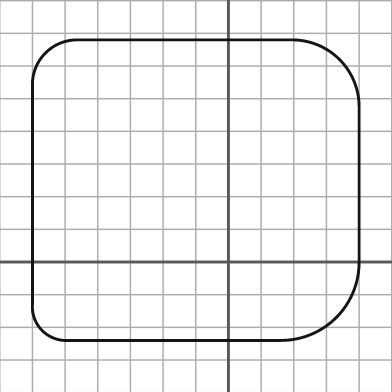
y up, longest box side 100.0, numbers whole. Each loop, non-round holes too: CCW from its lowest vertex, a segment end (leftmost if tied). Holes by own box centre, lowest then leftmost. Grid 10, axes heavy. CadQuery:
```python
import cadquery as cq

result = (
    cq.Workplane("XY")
    .moveTo(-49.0, -24.0)
    .lineTo(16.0, -24.0)
    .threePointArc((33.0, -17.0), (40.0, 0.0))
    .lineTo(40.0, 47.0)
    .threePointArc((34.0, 62.0), (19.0, 68.0))
    .lineTo(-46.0, 68.0)
    .threePointArc((-56.0, 64.0), (-60.0, 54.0))
    .lineTo(-60.0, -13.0)
    .threePointArc((-57.0, -21.0), (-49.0, -24.0))
    .close()
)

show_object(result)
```